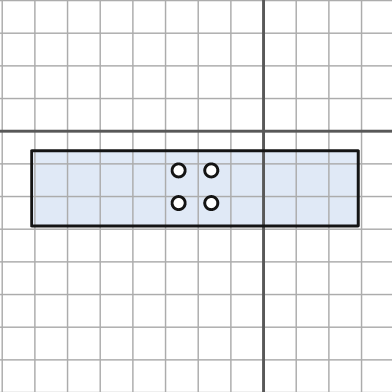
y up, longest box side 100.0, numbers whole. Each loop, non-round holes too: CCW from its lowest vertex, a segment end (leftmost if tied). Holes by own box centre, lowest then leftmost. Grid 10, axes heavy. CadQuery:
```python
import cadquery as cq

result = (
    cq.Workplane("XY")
    .moveTo(-71.0, -29.0)
    .lineTo(29.0, -29.0)
    .lineTo(29.0, -6.0)
    .lineTo(-71.0, -6.0)
    .close()
    .moveTo(-26.0, -22.0)
    .circle(2.0)
    .moveTo(-16.0, -22.0)
    .circle(2.0)
    .moveTo(-26.0, -12.0)
    .circle(2.0)
    .moveTo(-16.0, -12.0)
    .circle(2.0)
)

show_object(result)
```